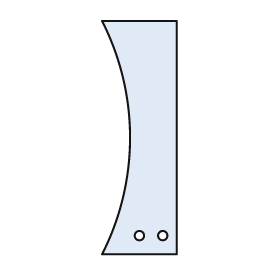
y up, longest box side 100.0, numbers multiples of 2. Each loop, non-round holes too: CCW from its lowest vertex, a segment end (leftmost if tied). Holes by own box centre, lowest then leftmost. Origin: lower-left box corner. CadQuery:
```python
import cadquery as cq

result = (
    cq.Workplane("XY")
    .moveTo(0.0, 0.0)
    .lineTo(32.0, 0.0)
    .lineTo(32.0, 100.0)
    .lineTo(0.0, 100.0)
    .threePointArc((12.0, 50.0), (0.0, 0.0))
    .close()
    .moveTo(16.0, 8.0)
    .circle(2.0)
    .moveTo(26.0, 8.0)
    .circle(2.0)
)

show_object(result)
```